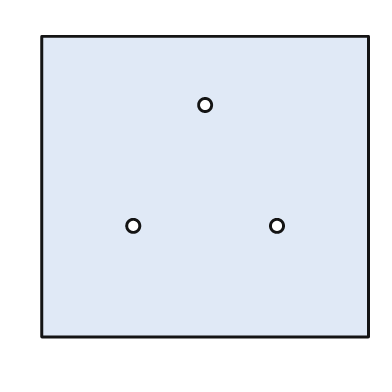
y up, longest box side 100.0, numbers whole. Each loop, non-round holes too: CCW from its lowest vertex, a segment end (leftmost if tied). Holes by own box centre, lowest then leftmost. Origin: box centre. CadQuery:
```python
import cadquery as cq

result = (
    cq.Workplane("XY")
    .moveTo(-50.0, -46.0)
    .lineTo(50.0, -46.0)
    .lineTo(50.0, 46.0)
    .lineTo(-50.0, 46.0)
    .close()
    .moveTo(-22.0, -12.0)
    .circle(2.0)
    .moveTo(22.0, -12.0)
    .circle(2.0)
    .moveTo(0.0, 25.0)
    .circle(2.0)
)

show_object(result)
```